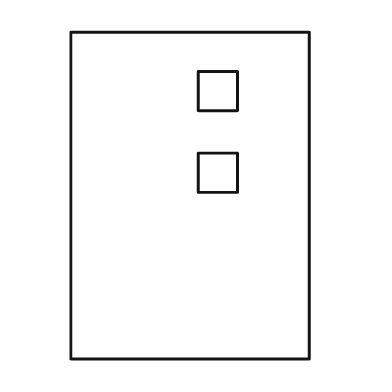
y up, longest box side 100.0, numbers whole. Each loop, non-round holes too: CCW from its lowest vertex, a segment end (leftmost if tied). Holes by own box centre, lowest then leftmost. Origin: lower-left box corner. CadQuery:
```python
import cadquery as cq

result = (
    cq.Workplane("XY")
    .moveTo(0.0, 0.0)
    .lineTo(73.0, 0.0)
    .lineTo(73.0, 100.0)
    .lineTo(0.0, 100.0)
    .close()
    .moveTo(39.0, 51.0)
    .lineTo(51.0, 51.0)
    .lineTo(51.0, 63.0)
    .lineTo(39.0, 63.0)
    .close()
    .moveTo(39.0, 76.0)
    .lineTo(51.0, 76.0)
    .lineTo(51.0, 88.0)
    .lineTo(39.0, 88.0)
    .close()
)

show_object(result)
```